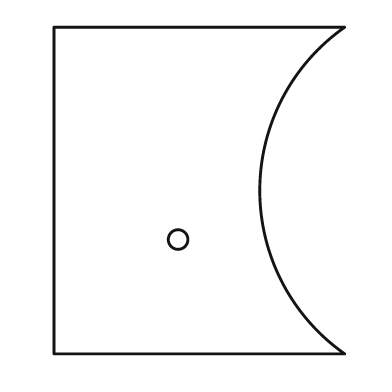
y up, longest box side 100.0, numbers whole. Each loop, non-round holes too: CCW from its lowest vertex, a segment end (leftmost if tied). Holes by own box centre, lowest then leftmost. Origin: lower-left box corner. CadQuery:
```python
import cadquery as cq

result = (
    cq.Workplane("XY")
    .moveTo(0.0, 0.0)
    .lineTo(89.0, 0.0)
    .threePointArc((63.0, 50.0), (89.0, 100.0))
    .lineTo(0.0, 100.0)
    .close()
    .moveTo(38.0, 35.0)
    .circle(3.0)
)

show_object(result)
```